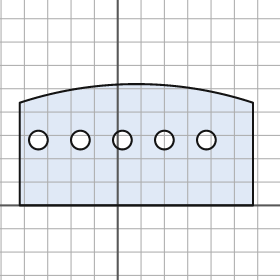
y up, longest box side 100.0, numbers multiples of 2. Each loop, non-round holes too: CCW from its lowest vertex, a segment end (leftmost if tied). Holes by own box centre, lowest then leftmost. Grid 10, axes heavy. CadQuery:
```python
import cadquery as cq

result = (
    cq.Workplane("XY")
    .moveTo(-42.0, 0.0)
    .lineTo(58.0, 0.0)
    .lineTo(58.0, 44.0)
    .threePointArc((8.0, 52.0), (-42.0, 44.0))
    .close()
    .moveTo(-34.0, 28.0)
    .circle(4.0)
    .moveTo(-16.0, 28.0)
    .circle(4.0)
    .moveTo(2.0, 28.0)
    .circle(4.0)
    .moveTo(20.0, 28.0)
    .circle(4.0)
    .moveTo(38.0, 28.0)
    .circle(4.0)
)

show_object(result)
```